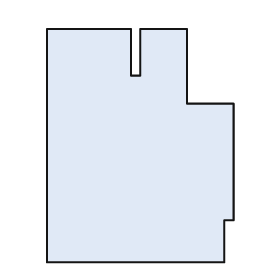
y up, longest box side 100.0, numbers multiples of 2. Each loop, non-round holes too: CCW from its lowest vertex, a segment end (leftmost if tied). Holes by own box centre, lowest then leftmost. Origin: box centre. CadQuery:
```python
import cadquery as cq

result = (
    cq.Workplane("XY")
    .moveTo(-40.0, -50.0)
    .lineTo(36.0, -50.0)
    .lineTo(36.0, -32.0)
    .lineTo(40.0, -32.0)
    .lineTo(40.0, 18.0)
    .lineTo(20.0, 18.0)
    .lineTo(20.0, 50.0)
    .lineTo(0.0, 50.0)
    .lineTo(0.0, 30.0)
    .lineTo(-4.0, 30.0)
    .lineTo(-4.0, 50.0)
    .lineTo(-40.0, 50.0)
    .close()
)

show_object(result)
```